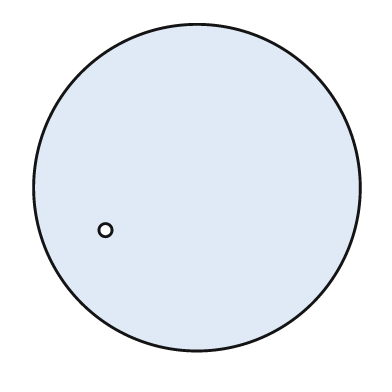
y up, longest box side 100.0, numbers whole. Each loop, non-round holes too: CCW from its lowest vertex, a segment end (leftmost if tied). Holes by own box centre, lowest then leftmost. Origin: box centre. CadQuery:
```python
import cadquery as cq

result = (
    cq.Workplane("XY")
    .moveTo(0.0, 0.0)
    .circle(50.0)
    .moveTo(-28.0, -13.0)
    .circle(2.0)
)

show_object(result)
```